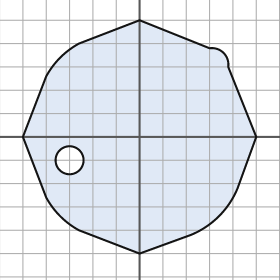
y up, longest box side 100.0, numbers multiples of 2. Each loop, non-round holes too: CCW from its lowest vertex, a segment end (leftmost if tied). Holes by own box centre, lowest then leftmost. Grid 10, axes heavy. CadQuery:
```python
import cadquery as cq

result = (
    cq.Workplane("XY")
    .moveTo(0.0, -50.0)
    .lineTo(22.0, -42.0)
    .threePointArc((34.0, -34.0), (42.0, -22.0))
    .lineTo(50.0, 0.0)
    .lineTo(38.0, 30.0)
    .threePointArc((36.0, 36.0), (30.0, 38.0))
    .lineTo(0.0, 50.0)
    .lineTo(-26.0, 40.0)
    .threePointArc((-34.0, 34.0), (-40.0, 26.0))
    .lineTo(-50.0, 0.0)
    .lineTo(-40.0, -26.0)
    .threePointArc((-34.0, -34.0), (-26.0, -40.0))
    .close()
    .moveTo(-30.0, -10.0)
    .circle(6.0)
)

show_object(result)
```